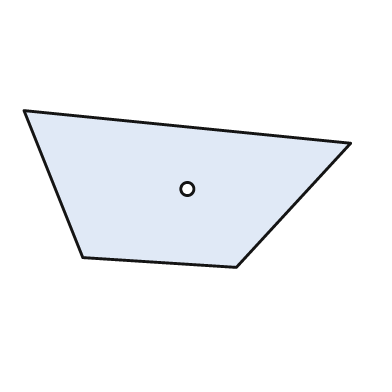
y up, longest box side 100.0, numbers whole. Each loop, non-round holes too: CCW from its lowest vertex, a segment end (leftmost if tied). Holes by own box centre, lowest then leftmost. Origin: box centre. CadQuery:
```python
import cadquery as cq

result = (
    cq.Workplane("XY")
    .moveTo(15.0, -24.0)
    .lineTo(50.0, 14.0)
    .lineTo(-50.0, 24.0)
    .lineTo(-32.0, -21.0)
    .close()
    .moveTo(0.0, 0.0)
    .circle(2.0)
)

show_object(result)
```